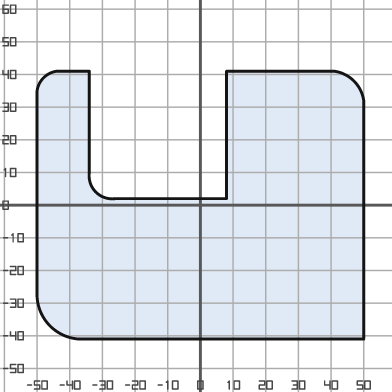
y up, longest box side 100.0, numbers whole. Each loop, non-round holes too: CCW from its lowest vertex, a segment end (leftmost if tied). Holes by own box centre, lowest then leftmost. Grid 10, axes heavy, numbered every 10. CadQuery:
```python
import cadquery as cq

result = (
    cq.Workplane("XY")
    .moveTo(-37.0, -41.0)
    .lineTo(50.0, -41.0)
    .lineTo(50.0, 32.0)
    .threePointArc((47.0, 38.0), (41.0, 41.0))
    .lineTo(8.0, 41.0)
    .lineTo(8.0, 2.0)
    .lineTo(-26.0, 2.0)
    .threePointArc((-32.0, 4.0), (-34.0, 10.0))
    .lineTo(-34.0, 41.0)
    .lineTo(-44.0, 41.0)
    .threePointArc((-48.0, 39.0), (-50.0, 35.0))
    .lineTo(-50.0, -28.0)
    .threePointArc((-46.0, -37.0), (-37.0, -41.0))
    .close()
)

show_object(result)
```